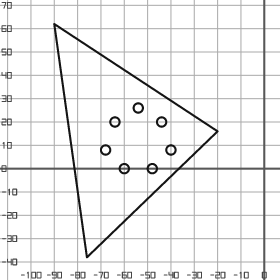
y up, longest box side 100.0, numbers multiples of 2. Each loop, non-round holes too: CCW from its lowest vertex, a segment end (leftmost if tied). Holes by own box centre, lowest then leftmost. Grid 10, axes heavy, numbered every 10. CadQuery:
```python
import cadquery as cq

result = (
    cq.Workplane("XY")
    .moveTo(-76.0, -38.0)
    .lineTo(-20.0, 16.0)
    .lineTo(-90.0, 62.0)
    .close()
    .moveTo(-60.0, 0.0)
    .circle(2.0)
    .moveTo(-48.0, 0.0)
    .circle(2.0)
    .moveTo(-68.0, 8.0)
    .circle(2.0)
    .moveTo(-40.0, 8.0)
    .circle(2.0)
    .moveTo(-64.0, 20.0)
    .circle(2.0)
    .moveTo(-44.0, 20.0)
    .circle(2.0)
    .moveTo(-54.0, 26.0)
    .circle(2.0)
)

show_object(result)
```